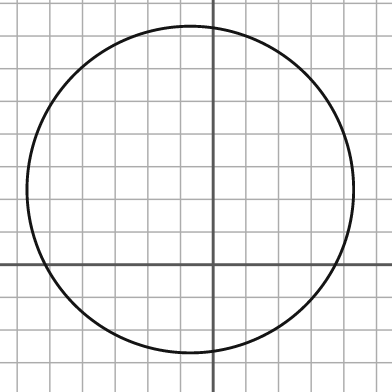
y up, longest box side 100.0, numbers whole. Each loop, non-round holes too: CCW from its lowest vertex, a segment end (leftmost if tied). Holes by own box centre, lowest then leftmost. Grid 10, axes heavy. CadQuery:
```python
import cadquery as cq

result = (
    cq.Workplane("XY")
    .moveTo(-7.0, 23.0)
    .circle(50.0)
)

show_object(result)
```